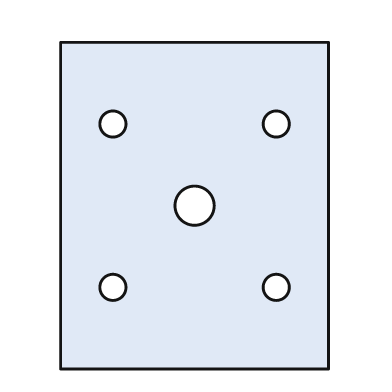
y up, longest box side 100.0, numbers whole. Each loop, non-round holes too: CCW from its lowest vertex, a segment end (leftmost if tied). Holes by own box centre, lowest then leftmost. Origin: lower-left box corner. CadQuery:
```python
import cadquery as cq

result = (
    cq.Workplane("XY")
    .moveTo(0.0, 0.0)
    .lineTo(82.0, 0.0)
    .lineTo(82.0, 100.0)
    .lineTo(0.0, 100.0)
    .close()
    .moveTo(16.0, 25.0)
    .circle(4.0)
    .moveTo(66.0, 25.0)
    .circle(4.0)
    .moveTo(41.0, 50.0)
    .circle(6.0)
    .moveTo(16.0, 75.0)
    .circle(4.0)
    .moveTo(66.0, 75.0)
    .circle(4.0)
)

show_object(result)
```